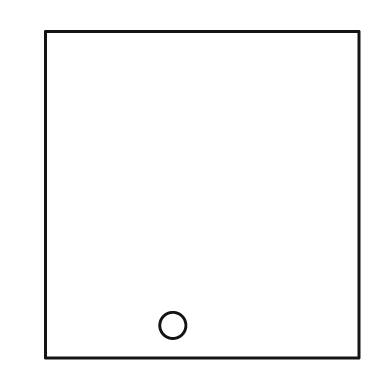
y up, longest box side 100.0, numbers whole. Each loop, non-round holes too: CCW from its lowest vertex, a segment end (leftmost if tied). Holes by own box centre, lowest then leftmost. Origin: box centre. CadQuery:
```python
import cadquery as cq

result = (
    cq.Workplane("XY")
    .moveTo(-48.0, -50.0)
    .lineTo(48.0, -50.0)
    .lineTo(48.0, 50.0)
    .lineTo(-48.0, 50.0)
    .close()
    .moveTo(-9.0, -40.0)
    .circle(4.0)
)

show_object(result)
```